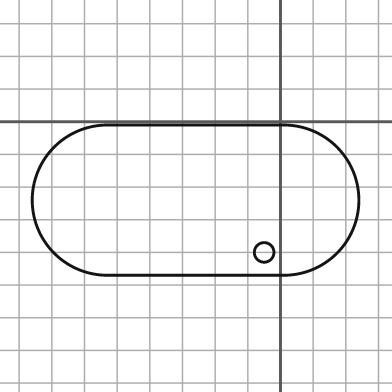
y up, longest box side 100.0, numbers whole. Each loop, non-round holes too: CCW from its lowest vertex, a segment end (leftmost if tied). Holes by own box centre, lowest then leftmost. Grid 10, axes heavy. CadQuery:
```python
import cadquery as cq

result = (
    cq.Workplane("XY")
    .moveTo(-53.0, -47.0)
    .lineTo(1.0, -47.0)
    .threePointArc((24.0, -24.0), (1.0, -1.0))
    .lineTo(-53.0, -1.0)
    .threePointArc((-76.0, -24.0), (-53.0, -47.0))
    .close()
    .moveTo(-5.0, -40.0)
    .circle(3.0)
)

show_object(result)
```